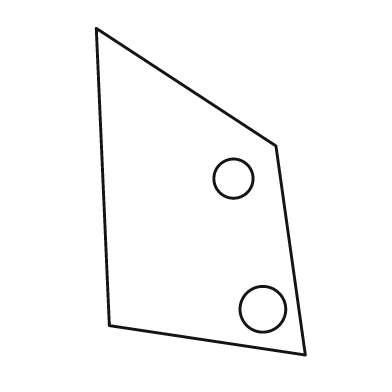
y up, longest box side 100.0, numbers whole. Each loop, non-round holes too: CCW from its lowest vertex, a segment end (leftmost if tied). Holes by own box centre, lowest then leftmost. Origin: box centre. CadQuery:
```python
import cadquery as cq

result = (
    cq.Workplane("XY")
    .moveTo(32.0, -50.0)
    .lineTo(23.0, 14.0)
    .lineTo(-32.0, 50.0)
    .lineTo(-28.0, -41.0)
    .close()
    .moveTo(19.0, -36.0)
    .circle(7.0)
    .moveTo(10.0, 4.0)
    .circle(6.0)
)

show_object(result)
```